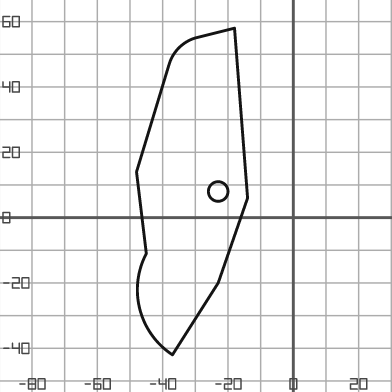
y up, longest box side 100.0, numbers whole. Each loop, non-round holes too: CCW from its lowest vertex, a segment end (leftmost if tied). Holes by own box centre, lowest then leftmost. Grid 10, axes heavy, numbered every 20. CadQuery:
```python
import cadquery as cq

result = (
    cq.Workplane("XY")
    .moveTo(-37.0, -42.0)
    .lineTo(-23.0, -20.0)
    .lineTo(-14.0, 6.0)
    .lineTo(-18.0, 58.0)
    .lineTo(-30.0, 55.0)
    .threePointArc((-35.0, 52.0), (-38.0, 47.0))
    .lineTo(-48.0, 14.0)
    .lineTo(-45.0, -11.0)
    .threePointArc((-47.0, -28.0), (-37.0, -42.0))
    .close()
    .moveTo(-23.0, 8.0)
    .circle(3.0)
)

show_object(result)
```